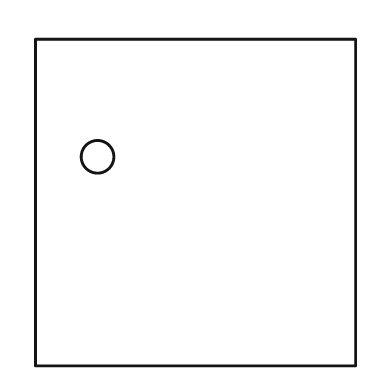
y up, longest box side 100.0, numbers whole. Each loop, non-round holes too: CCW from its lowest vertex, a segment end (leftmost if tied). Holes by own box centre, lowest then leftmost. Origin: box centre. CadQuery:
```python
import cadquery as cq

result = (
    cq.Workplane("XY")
    .moveTo(-49.0, -50.0)
    .lineTo(49.0, -50.0)
    .lineTo(49.0, 50.0)
    .lineTo(-49.0, 50.0)
    .close()
    .moveTo(-30.0, 14.0)
    .circle(5.0)
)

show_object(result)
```